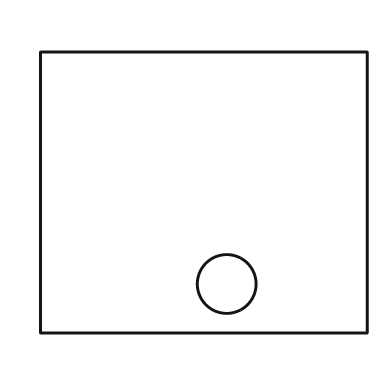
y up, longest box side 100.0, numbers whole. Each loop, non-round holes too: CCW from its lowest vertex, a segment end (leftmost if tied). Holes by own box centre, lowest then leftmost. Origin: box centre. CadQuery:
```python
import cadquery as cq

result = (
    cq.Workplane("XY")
    .moveTo(-50.0, -43.0)
    .lineTo(50.0, -43.0)
    .lineTo(50.0, 43.0)
    .lineTo(-50.0, 43.0)
    .close()
    .moveTo(7.0, -28.0)
    .circle(9.0)
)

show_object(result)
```